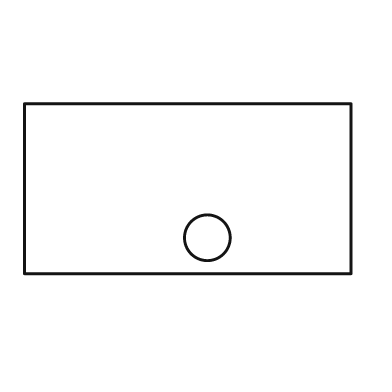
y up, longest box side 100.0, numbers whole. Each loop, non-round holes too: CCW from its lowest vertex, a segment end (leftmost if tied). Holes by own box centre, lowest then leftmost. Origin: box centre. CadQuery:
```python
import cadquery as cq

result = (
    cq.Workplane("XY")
    .moveTo(-50.0, -26.0)
    .lineTo(50.0, -26.0)
    .lineTo(50.0, 26.0)
    .lineTo(-50.0, 26.0)
    .close()
    .moveTo(6.0, -15.0)
    .circle(7.0)
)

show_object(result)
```